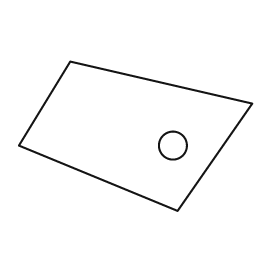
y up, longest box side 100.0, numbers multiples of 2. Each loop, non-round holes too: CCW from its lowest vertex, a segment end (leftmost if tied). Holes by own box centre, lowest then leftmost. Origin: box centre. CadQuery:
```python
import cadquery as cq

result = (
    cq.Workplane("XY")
    .moveTo(18.0, -32.0)
    .lineTo(50.0, 14.0)
    .lineTo(-28.0, 32.0)
    .lineTo(-50.0, -4.0)
    .close()
    .moveTo(16.0, -4.0)
    .circle(6.0)
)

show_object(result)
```